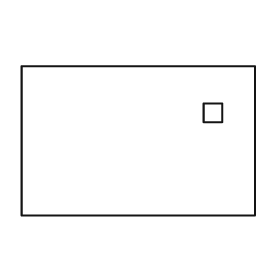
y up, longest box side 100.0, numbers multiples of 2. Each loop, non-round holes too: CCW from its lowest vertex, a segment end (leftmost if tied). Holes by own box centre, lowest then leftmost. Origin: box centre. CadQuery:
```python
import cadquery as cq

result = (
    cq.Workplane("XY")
    .moveTo(-50.0, -32.0)
    .lineTo(50.0, -32.0)
    .lineTo(50.0, 32.0)
    .lineTo(-50.0, 32.0)
    .close()
    .moveTo(28.0, 8.0)
    .lineTo(36.0, 8.0)
    .lineTo(36.0, 16.0)
    .lineTo(28.0, 16.0)
    .close()
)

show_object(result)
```